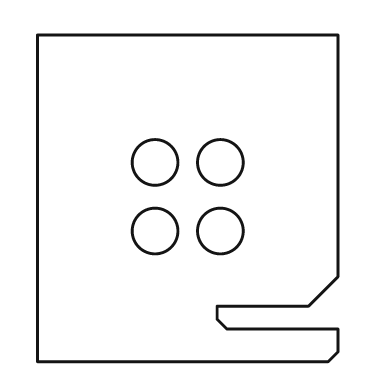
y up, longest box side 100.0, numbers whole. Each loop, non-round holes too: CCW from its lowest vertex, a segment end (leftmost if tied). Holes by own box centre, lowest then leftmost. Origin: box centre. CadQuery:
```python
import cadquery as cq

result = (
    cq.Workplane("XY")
    .moveTo(-46.0, -50.0)
    .lineTo(43.0, -50.0)
    .lineTo(46.0, -47.0)
    .lineTo(46.0, -40.0)
    .lineTo(12.0, -40.0)
    .lineTo(9.0, -37.0)
    .lineTo(9.0, -33.0)
    .lineTo(37.0, -33.0)
    .lineTo(46.0, -24.0)
    .lineTo(46.0, 50.0)
    .lineTo(-46.0, 50.0)
    .close()
    .moveTo(-10.0, -10.0)
    .circle(7.0)
    .moveTo(10.0, -10.0)
    .circle(7.0)
    .moveTo(-10.0, 11.0)
    .circle(7.0)
    .moveTo(10.0, 11.0)
    .circle(7.0)
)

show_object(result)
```